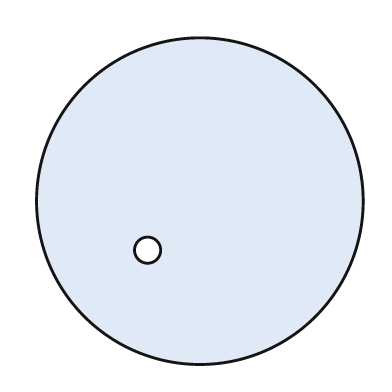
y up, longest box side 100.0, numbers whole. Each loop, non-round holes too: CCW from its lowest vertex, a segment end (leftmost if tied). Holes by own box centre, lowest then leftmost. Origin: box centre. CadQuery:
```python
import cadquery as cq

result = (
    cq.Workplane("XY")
    .moveTo(0.0, 0.0)
    .circle(50.0)
    .moveTo(-16.0, -15.0)
    .circle(4.0)
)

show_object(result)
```